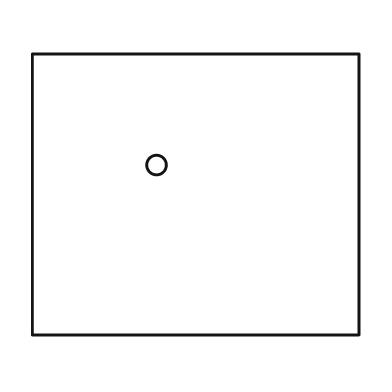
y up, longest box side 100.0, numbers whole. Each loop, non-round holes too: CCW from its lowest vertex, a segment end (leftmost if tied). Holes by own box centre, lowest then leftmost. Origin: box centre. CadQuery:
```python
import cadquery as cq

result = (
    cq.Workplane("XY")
    .moveTo(-50.0, -43.0)
    .lineTo(50.0, -43.0)
    .lineTo(50.0, 43.0)
    .lineTo(-50.0, 43.0)
    .close()
    .moveTo(-12.0, 9.0)
    .circle(3.0)
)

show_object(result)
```